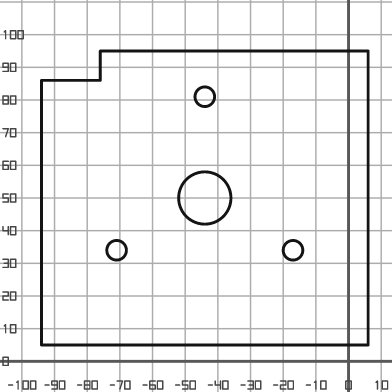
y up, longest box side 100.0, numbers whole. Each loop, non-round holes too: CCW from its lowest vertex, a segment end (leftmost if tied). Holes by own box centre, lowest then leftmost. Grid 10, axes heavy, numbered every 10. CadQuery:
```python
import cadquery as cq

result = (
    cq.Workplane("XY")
    .moveTo(-94.0, 5.0)
    .lineTo(6.0, 5.0)
    .lineTo(6.0, 95.0)
    .lineTo(-76.0, 95.0)
    .lineTo(-76.0, 86.0)
    .lineTo(-94.0, 86.0)
    .close()
    .moveTo(-71.0, 34.0)
    .circle(3.0)
    .moveTo(-17.0, 34.0)
    .circle(3.0)
    .moveTo(-44.0, 50.0)
    .circle(8.0)
    .moveTo(-44.0, 81.0)
    .circle(3.0)
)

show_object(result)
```